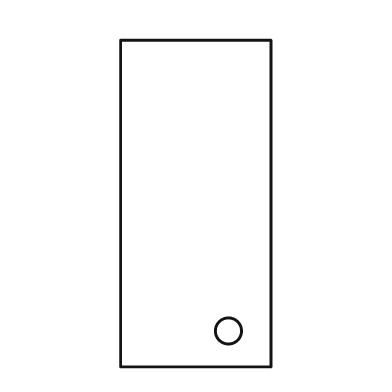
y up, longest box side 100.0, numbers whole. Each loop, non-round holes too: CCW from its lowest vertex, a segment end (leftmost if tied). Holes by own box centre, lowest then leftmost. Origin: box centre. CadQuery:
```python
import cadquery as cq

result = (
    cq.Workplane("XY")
    .moveTo(-23.0, -50.0)
    .lineTo(23.0, -50.0)
    .lineTo(23.0, 50.0)
    .lineTo(-23.0, 50.0)
    .close()
    .moveTo(10.0, -39.0)
    .circle(4.0)
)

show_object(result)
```